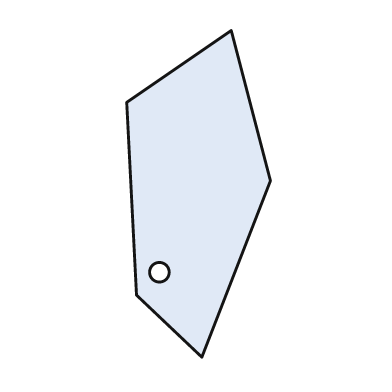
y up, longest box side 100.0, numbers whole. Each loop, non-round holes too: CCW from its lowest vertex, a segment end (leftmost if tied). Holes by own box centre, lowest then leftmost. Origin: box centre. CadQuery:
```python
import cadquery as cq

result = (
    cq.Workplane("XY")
    .moveTo(1.0, -50.0)
    .lineTo(22.0, 4.0)
    .lineTo(10.0, 50.0)
    .lineTo(-22.0, 28.0)
    .lineTo(-19.0, -31.0)
    .close()
    .moveTo(-12.0, -24.0)
    .circle(3.0)
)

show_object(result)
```